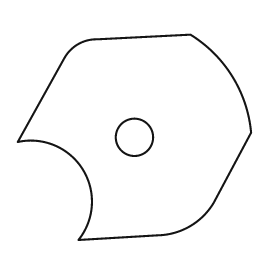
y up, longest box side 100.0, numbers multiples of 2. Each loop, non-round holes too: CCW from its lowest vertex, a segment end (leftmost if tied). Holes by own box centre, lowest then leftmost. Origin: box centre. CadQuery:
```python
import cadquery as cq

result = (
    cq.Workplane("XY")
    .moveTo(-24.0, -44.0)
    .lineTo(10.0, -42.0)
    .threePointArc((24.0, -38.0), (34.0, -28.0))
    .lineTo(50.0, 2.0)
    .threePointArc((42.0, 26.0), (24.0, 44.0))
    .lineTo(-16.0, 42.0)
    .threePointArc((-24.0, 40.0), (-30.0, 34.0))
    .lineTo(-50.0, -2.0)
    .threePointArc((-22.0, -14.0), (-24.0, -44.0))
    .close()
    .moveTo(0.0, 0.0)
    .circle(8.0)
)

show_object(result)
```